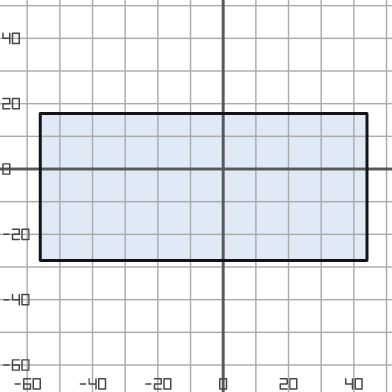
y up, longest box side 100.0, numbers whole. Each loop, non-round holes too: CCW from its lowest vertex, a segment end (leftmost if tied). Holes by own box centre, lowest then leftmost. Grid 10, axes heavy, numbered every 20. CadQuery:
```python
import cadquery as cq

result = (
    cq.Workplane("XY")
    .moveTo(-56.0, -28.0)
    .lineTo(44.0, -28.0)
    .lineTo(44.0, 17.0)
    .lineTo(-56.0, 17.0)
    .close()
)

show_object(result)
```